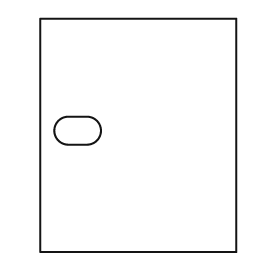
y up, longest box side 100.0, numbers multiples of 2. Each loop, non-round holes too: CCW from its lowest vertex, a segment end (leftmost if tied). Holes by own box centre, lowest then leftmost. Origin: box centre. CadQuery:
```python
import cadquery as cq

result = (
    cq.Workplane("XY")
    .moveTo(-42.0, -50.0)
    .lineTo(42.0, -50.0)
    .lineTo(42.0, 50.0)
    .lineTo(-42.0, 50.0)
    .close()
    .moveTo(-30.0, -4.0)
    .lineTo(-22.0, -4.0)
    .threePointArc((-16.0, 2.0), (-22.0, 8.0))
    .lineTo(-30.0, 8.0)
    .threePointArc((-36.0, 2.0), (-30.0, -4.0))
    .close()
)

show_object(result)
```